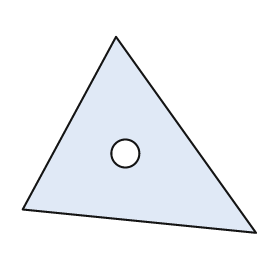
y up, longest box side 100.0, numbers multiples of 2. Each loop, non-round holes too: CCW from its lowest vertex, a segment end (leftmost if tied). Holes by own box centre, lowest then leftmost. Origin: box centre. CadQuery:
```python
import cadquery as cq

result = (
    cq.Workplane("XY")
    .moveTo(50.0, -42.0)
    .lineTo(-10.0, 42.0)
    .lineTo(-50.0, -32.0)
    .close()
    .moveTo(-6.0, -8.0)
    .circle(6.0)
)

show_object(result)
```